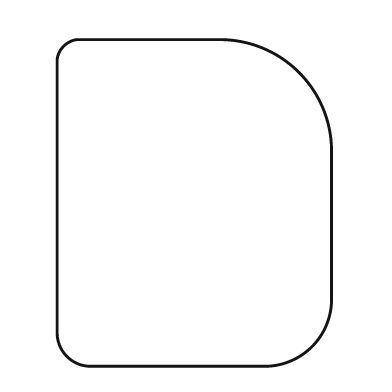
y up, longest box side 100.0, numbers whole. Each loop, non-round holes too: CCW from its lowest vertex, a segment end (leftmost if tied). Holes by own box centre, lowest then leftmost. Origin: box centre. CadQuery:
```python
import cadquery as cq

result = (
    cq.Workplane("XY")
    .moveTo(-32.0, -50.0)
    .lineTo(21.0, -50.0)
    .threePointArc((36.0, -44.0), (42.0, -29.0))
    .lineTo(42.0, 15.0)
    .threePointArc((32.0, 40.0), (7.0, 50.0))
    .lineTo(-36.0, 50.0)
    .threePointArc((-40.0, 48.0), (-42.0, 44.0))
    .lineTo(-42.0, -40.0)
    .threePointArc((-39.0, -47.0), (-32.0, -50.0))
    .close()
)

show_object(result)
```